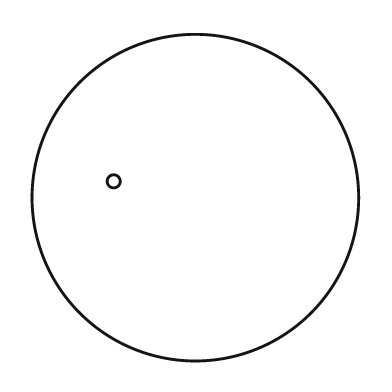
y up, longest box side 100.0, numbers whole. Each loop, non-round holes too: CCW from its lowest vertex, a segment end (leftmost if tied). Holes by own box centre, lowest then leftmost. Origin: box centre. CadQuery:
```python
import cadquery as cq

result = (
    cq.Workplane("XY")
    .moveTo(0.0, 0.0)
    .circle(50.0)
    .moveTo(-25.0, 5.0)
    .circle(2.0)
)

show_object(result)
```